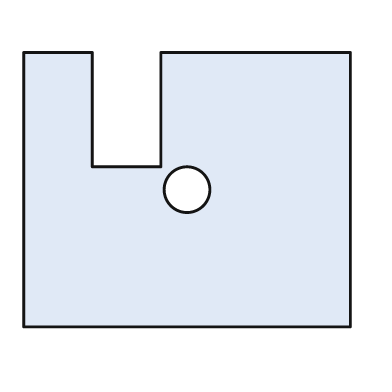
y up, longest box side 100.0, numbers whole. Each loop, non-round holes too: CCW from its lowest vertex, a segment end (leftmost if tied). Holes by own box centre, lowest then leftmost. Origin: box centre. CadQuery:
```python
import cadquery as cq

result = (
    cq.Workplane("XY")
    .moveTo(-50.0, -42.0)
    .lineTo(50.0, -42.0)
    .lineTo(50.0, 42.0)
    .lineTo(-8.0, 42.0)
    .lineTo(-8.0, 7.0)
    .lineTo(-29.0, 7.0)
    .lineTo(-29.0, 42.0)
    .lineTo(-50.0, 42.0)
    .close()
    .moveTo(0.0, 0.0)
    .circle(7.0)
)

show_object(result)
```